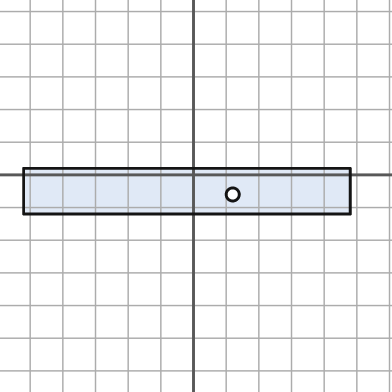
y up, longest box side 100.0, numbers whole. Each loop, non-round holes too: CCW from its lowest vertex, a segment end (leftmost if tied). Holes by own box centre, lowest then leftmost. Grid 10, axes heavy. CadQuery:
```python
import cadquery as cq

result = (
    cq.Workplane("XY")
    .moveTo(-52.0, -12.0)
    .lineTo(48.0, -12.0)
    .lineTo(48.0, 2.0)
    .lineTo(-52.0, 2.0)
    .close()
    .moveTo(12.0, -6.0)
    .circle(2.0)
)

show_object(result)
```